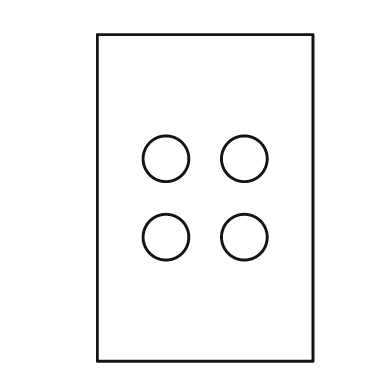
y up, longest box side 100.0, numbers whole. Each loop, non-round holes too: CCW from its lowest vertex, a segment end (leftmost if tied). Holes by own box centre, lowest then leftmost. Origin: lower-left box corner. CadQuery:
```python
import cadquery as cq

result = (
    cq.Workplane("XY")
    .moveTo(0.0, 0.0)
    .lineTo(66.0, 0.0)
    .lineTo(66.0, 100.0)
    .lineTo(0.0, 100.0)
    .close()
    .moveTo(21.0, 38.0)
    .circle(7.0)
    .moveTo(45.0, 38.0)
    .circle(7.0)
    .moveTo(21.0, 62.0)
    .circle(7.0)
    .moveTo(45.0, 62.0)
    .circle(7.0)
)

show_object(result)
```